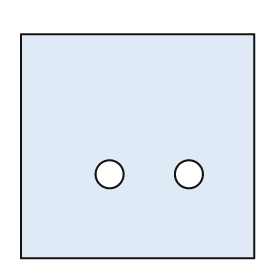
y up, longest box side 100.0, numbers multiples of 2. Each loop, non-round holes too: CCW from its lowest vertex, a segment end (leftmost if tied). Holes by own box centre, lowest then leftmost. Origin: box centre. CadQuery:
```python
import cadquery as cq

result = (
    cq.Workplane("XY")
    .moveTo(-50.0, -48.0)
    .lineTo(50.0, -48.0)
    .lineTo(50.0, 48.0)
    .lineTo(-50.0, 48.0)
    .close()
    .moveTo(-12.0, -12.0)
    .circle(6.0)
    .moveTo(22.0, -12.0)
    .circle(6.0)
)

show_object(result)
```